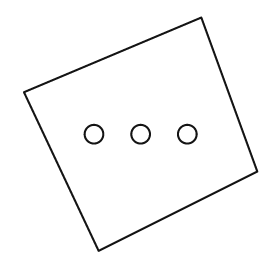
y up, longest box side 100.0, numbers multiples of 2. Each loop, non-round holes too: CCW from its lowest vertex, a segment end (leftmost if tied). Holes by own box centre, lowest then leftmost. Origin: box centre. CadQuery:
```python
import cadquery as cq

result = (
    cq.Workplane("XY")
    .moveTo(-18.0, -50.0)
    .lineTo(50.0, -16.0)
    .lineTo(26.0, 50.0)
    .lineTo(-50.0, 18.0)
    .close()
    .moveTo(-20.0, 0.0)
    .circle(4.0)
    .moveTo(0.0, 0.0)
    .circle(4.0)
    .moveTo(20.0, 0.0)
    .circle(4.0)
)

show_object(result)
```